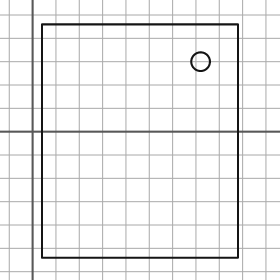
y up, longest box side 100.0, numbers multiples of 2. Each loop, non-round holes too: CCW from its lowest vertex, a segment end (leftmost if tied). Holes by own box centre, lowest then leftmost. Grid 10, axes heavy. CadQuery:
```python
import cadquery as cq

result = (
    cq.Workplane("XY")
    .moveTo(4.0, -54.0)
    .lineTo(88.0, -54.0)
    .lineTo(88.0, 46.0)
    .lineTo(4.0, 46.0)
    .close()
    .moveTo(72.0, 30.0)
    .circle(4.0)
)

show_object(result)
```